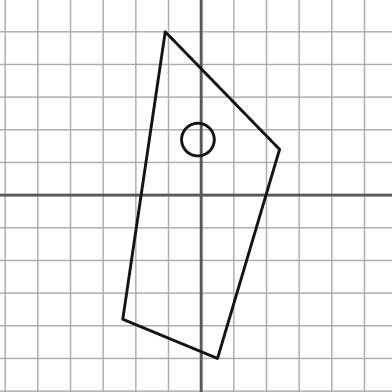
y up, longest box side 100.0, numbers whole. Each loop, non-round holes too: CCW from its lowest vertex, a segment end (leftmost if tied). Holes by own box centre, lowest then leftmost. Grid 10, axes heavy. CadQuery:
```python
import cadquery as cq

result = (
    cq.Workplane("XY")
    .moveTo(5.0, -50.0)
    .lineTo(24.0, 14.0)
    .lineTo(-11.0, 50.0)
    .lineTo(-24.0, -38.0)
    .close()
    .moveTo(-1.0, 17.0)
    .circle(5.0)
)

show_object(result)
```